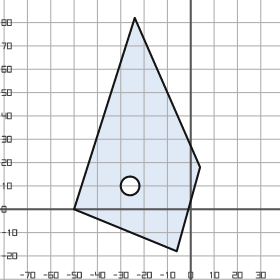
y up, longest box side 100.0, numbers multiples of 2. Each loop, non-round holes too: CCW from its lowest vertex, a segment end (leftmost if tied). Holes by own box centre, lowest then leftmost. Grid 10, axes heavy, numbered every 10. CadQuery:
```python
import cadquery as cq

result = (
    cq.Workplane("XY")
    .moveTo(-6.0, -18.0)
    .lineTo(4.0, 18.0)
    .lineTo(-24.0, 82.0)
    .lineTo(-50.0, 0.0)
    .close()
    .moveTo(-26.0, 10.0)
    .circle(4.0)
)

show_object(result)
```